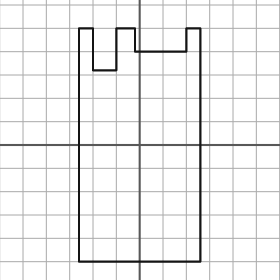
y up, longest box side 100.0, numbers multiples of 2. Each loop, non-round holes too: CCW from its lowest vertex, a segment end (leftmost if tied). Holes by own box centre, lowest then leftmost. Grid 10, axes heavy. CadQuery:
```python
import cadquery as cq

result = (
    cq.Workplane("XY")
    .moveTo(-26.0, -50.0)
    .lineTo(26.0, -50.0)
    .lineTo(26.0, 50.0)
    .lineTo(20.0, 50.0)
    .lineTo(20.0, 40.0)
    .lineTo(-2.0, 40.0)
    .lineTo(-2.0, 50.0)
    .lineTo(-10.0, 50.0)
    .lineTo(-10.0, 32.0)
    .lineTo(-20.0, 32.0)
    .lineTo(-20.0, 50.0)
    .lineTo(-26.0, 50.0)
    .close()
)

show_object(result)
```